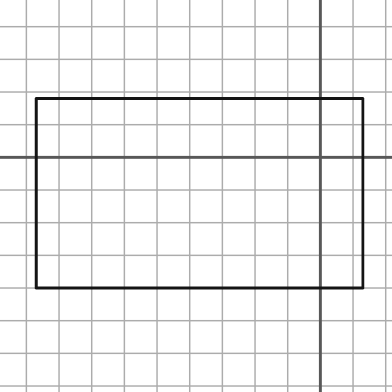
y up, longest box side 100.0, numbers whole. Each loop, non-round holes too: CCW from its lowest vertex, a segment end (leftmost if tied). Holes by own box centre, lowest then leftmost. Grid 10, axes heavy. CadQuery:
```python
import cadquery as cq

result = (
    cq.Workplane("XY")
    .moveTo(-87.0, -40.0)
    .lineTo(13.0, -40.0)
    .lineTo(13.0, 18.0)
    .lineTo(-87.0, 18.0)
    .close()
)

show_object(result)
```